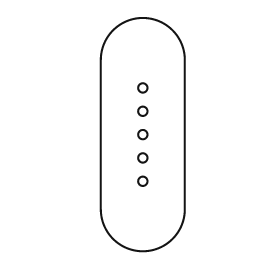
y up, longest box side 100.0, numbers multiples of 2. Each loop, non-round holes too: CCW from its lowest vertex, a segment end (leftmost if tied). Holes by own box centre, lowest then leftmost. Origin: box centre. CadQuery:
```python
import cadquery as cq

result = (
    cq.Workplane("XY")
    .moveTo(-18.0, -32.0)
    .threePointArc((0.0, -50.0), (18.0, -32.0))
    .lineTo(18.0, 32.0)
    .threePointArc((0.0, 50.0), (-18.0, 32.0))
    .close()
    .moveTo(0.0, -20.0)
    .circle(2.0)
    .moveTo(0.0, -10.0)
    .circle(2.0)
    .moveTo(0.0, 0.0)
    .circle(2.0)
    .moveTo(0.0, 10.0)
    .circle(2.0)
    .moveTo(0.0, 20.0)
    .circle(2.0)
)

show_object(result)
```